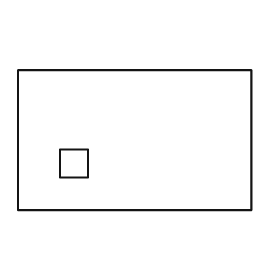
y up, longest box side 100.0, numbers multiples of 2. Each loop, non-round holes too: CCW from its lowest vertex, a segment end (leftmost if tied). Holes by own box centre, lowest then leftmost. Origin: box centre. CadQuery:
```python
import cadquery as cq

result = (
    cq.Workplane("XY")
    .moveTo(-50.0, -30.0)
    .lineTo(50.0, -30.0)
    .lineTo(50.0, 30.0)
    .lineTo(-50.0, 30.0)
    .close()
    .moveTo(-32.0, -16.0)
    .lineTo(-20.0, -16.0)
    .lineTo(-20.0, -4.0)
    .lineTo(-32.0, -4.0)
    .close()
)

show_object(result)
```